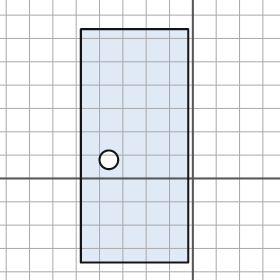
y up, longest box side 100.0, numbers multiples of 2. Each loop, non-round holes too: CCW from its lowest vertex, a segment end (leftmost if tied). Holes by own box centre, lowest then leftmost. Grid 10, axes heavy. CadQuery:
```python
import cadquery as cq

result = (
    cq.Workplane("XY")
    .moveTo(-48.0, -36.0)
    .lineTo(-2.0, -36.0)
    .lineTo(-2.0, 64.0)
    .lineTo(-48.0, 64.0)
    .close()
    .moveTo(-36.0, 8.0)
    .circle(4.0)
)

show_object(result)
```